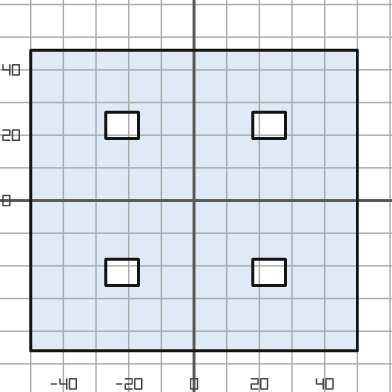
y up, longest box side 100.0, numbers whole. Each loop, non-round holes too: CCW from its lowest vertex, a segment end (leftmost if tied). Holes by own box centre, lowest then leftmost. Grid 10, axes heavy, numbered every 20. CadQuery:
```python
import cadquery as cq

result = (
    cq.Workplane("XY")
    .moveTo(-50.0, -46.0)
    .lineTo(50.0, -46.0)
    .lineTo(50.0, 46.0)
    .lineTo(-50.0, 46.0)
    .close()
    .moveTo(-27.0, -26.0)
    .lineTo(-17.0, -26.0)
    .lineTo(-17.0, -18.0)
    .lineTo(-27.0, -18.0)
    .close()
    .moveTo(18.0, -26.0)
    .lineTo(28.0, -26.0)
    .lineTo(28.0, -18.0)
    .lineTo(18.0, -18.0)
    .close()
    .moveTo(-27.0, 19.0)
    .lineTo(-17.0, 19.0)
    .lineTo(-17.0, 27.0)
    .lineTo(-27.0, 27.0)
    .close()
    .moveTo(18.0, 19.0)
    .lineTo(28.0, 19.0)
    .lineTo(28.0, 27.0)
    .lineTo(18.0, 27.0)
    .close()
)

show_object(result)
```